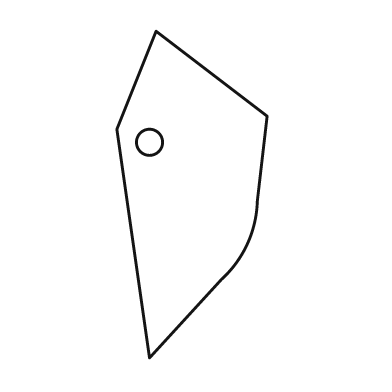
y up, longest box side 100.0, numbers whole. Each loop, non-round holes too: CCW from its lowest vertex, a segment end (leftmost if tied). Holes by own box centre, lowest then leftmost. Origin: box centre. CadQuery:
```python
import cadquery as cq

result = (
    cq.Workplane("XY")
    .moveTo(-13.0, -50.0)
    .lineTo(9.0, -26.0)
    .threePointArc((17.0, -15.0), (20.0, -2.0))
    .lineTo(23.0, 24.0)
    .lineTo(-11.0, 50.0)
    .lineTo(-23.0, 20.0)
    .close()
    .moveTo(-13.0, 16.0)
    .circle(4.0)
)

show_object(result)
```